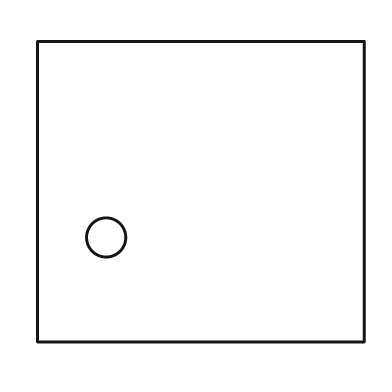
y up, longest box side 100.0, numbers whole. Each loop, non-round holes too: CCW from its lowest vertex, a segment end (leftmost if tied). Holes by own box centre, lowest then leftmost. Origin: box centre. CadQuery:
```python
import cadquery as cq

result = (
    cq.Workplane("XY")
    .moveTo(-50.0, -46.0)
    .lineTo(50.0, -46.0)
    .lineTo(50.0, 46.0)
    .lineTo(-50.0, 46.0)
    .close()
    .moveTo(-29.0, -14.0)
    .circle(6.0)
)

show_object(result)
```